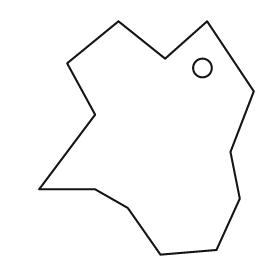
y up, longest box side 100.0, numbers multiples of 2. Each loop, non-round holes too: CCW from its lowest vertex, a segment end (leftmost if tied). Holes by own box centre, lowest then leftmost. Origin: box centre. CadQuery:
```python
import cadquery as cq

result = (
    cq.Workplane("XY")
    .moveTo(6.0, -50.0)
    .lineTo(30.0, -48.0)
    .lineTo(40.0, -26.0)
    .lineTo(36.0, -6.0)
    .lineTo(46.0, 20.0)
    .lineTo(26.0, 50.0)
    .lineTo(8.0, 34.0)
    .lineTo(-12.0, 50.0)
    .lineTo(-34.0, 32.0)
    .lineTo(-22.0, 10.0)
    .lineTo(-46.0, -22.0)
    .lineTo(-22.0, -22.0)
    .lineTo(-8.0, -30.0)
    .close()
    .moveTo(24.0, 30.0)
    .circle(4.0)
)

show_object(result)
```